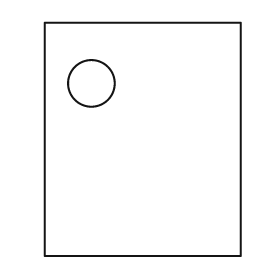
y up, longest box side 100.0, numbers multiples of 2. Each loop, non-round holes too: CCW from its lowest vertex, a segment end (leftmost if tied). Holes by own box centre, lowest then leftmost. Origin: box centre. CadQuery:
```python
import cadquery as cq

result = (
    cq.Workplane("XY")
    .moveTo(-42.0, -50.0)
    .lineTo(42.0, -50.0)
    .lineTo(42.0, 50.0)
    .lineTo(-42.0, 50.0)
    .close()
    .moveTo(-22.0, 24.0)
    .circle(10.0)
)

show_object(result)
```